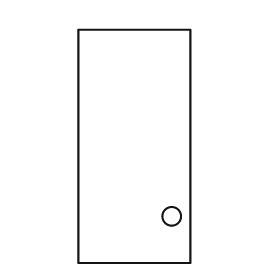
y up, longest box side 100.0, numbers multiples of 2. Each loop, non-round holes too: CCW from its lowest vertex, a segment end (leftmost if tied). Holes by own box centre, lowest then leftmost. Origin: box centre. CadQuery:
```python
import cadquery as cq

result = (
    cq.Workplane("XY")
    .moveTo(-24.0, -50.0)
    .lineTo(24.0, -50.0)
    .lineTo(24.0, 50.0)
    .lineTo(-24.0, 50.0)
    .close()
    .moveTo(16.0, -30.0)
    .circle(4.0)
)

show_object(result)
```